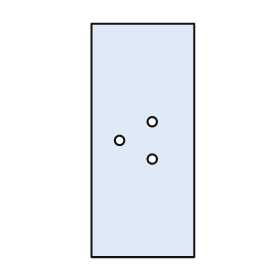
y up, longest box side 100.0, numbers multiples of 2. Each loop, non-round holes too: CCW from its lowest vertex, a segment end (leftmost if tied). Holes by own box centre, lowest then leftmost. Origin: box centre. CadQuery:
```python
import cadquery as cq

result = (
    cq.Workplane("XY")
    .moveTo(-22.0, -50.0)
    .lineTo(22.0, -50.0)
    .lineTo(22.0, 50.0)
    .lineTo(-22.0, 50.0)
    .close()
    .moveTo(4.0, -8.0)
    .circle(2.0)
    .moveTo(-10.0, 0.0)
    .circle(2.0)
    .moveTo(4.0, 8.0)
    .circle(2.0)
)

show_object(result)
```